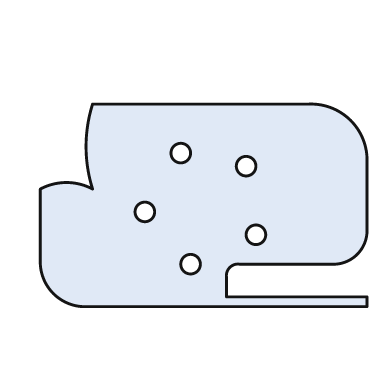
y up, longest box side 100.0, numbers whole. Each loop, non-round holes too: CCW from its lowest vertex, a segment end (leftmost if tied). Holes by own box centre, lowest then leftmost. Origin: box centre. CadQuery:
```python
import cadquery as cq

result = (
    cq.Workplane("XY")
    .moveTo(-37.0, -31.0)
    .lineTo(50.0, -31.0)
    .lineTo(50.0, -28.0)
    .lineTo(7.0, -28.0)
    .lineTo(7.0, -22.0)
    .threePointArc((8.0, -19.0), (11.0, -18.0))
    .lineTo(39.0, -18.0)
    .threePointArc((47.0, -15.0), (50.0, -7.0))
    .lineTo(50.0, 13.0)
    .threePointArc((45.0, 26.0), (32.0, 31.0))
    .lineTo(-34.0, 31.0)
    .threePointArc((-36.0, 18.0), (-34.0, 5.0))
    .threePointArc((-42.0, 7.0), (-50.0, 5.0))
    .lineTo(-50.0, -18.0)
    .threePointArc((-46.0, -27.0), (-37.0, -31.0))
    .close()
    .moveTo(-4.0, -18.0)
    .circle(3.0)
    .moveTo(16.0, -9.0)
    .circle(3.0)
    .moveTo(-18.0, -2.0)
    .circle(3.0)
    .moveTo(13.0, 12.0)
    .circle(3.0)
    .moveTo(-7.0, 16.0)
    .circle(3.0)
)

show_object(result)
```